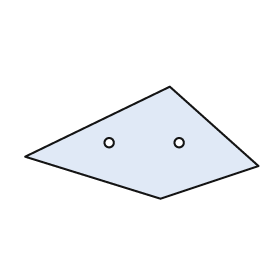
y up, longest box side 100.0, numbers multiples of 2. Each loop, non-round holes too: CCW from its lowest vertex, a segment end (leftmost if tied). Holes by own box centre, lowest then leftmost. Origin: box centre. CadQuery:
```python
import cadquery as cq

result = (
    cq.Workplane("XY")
    .moveTo(8.0, -24.0)
    .lineTo(50.0, -10.0)
    .lineTo(12.0, 24.0)
    .lineTo(-50.0, -6.0)
    .close()
    .moveTo(-14.0, 0.0)
    .circle(2.0)
    .moveTo(16.0, 0.0)
    .circle(2.0)
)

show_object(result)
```